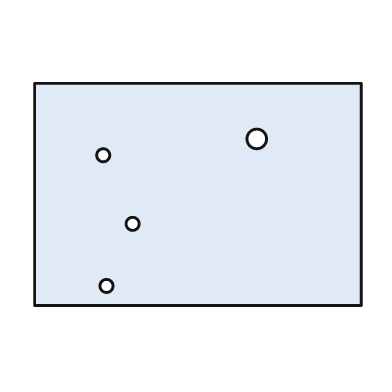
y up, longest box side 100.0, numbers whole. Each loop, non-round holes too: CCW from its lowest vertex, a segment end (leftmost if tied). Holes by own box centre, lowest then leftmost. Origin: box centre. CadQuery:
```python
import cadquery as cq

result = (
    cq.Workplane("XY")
    .moveTo(-50.0, -34.0)
    .lineTo(50.0, -34.0)
    .lineTo(50.0, 34.0)
    .lineTo(-50.0, 34.0)
    .close()
    .moveTo(-28.0, -28.0)
    .circle(2.0)
    .moveTo(-20.0, -9.0)
    .circle(2.0)
    .moveTo(-29.0, 12.0)
    .circle(2.0)
    .moveTo(18.0, 17.0)
    .circle(3.0)
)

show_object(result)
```